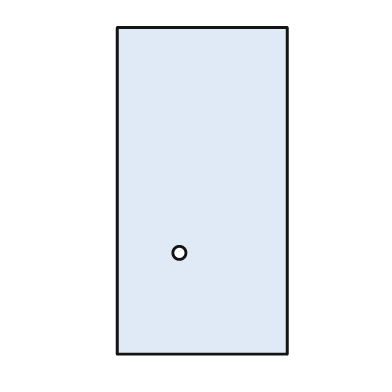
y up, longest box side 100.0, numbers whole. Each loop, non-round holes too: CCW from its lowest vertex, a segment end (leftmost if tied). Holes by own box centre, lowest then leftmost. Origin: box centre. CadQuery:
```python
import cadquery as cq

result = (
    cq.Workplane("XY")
    .moveTo(-26.0, -50.0)
    .lineTo(26.0, -50.0)
    .lineTo(26.0, 50.0)
    .lineTo(-26.0, 50.0)
    .close()
    .moveTo(-7.0, -19.0)
    .circle(2.0)
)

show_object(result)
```